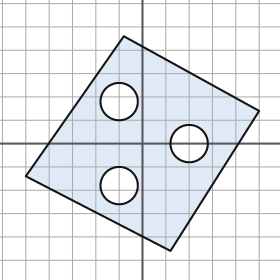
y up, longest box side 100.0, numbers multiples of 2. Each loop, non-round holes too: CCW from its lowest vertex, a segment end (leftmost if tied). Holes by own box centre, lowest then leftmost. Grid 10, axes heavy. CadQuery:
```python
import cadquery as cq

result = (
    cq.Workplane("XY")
    .moveTo(12.0, -46.0)
    .lineTo(50.0, 14.0)
    .lineTo(-8.0, 46.0)
    .lineTo(-50.0, -14.0)
    .close()
    .moveTo(-10.0, -18.0)
    .circle(8.0)
    .moveTo(20.0, 0.0)
    .circle(8.0)
    .moveTo(-10.0, 18.0)
    .circle(8.0)
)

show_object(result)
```